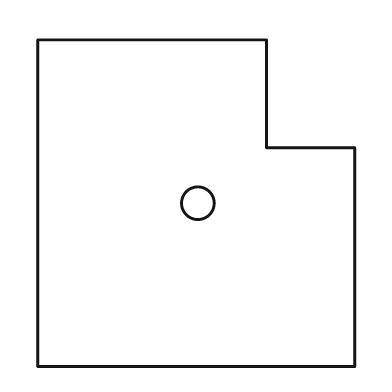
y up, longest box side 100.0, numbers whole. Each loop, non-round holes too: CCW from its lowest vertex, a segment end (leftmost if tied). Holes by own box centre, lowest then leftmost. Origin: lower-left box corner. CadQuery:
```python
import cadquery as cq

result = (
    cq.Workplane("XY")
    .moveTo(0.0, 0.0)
    .lineTo(97.0, 0.0)
    .lineTo(97.0, 67.0)
    .lineTo(70.0, 67.0)
    .lineTo(70.0, 100.0)
    .lineTo(0.0, 100.0)
    .close()
    .moveTo(49.0, 50.0)
    .circle(5.0)
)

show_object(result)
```